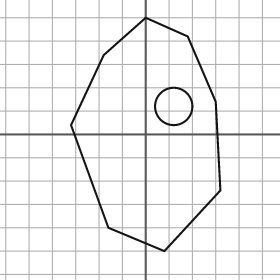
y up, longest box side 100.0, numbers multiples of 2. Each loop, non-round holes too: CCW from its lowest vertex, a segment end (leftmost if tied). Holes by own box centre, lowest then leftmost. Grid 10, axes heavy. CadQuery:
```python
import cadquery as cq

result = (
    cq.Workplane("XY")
    .moveTo(8.0, -50.0)
    .lineTo(32.0, -24.0)
    .lineTo(30.0, 14.0)
    .lineTo(18.0, 42.0)
    .lineTo(0.0, 50.0)
    .lineTo(-18.0, 34.0)
    .lineTo(-32.0, 4.0)
    .lineTo(-16.0, -40.0)
    .close()
    .moveTo(12.0, 12.0)
    .circle(8.0)
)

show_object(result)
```